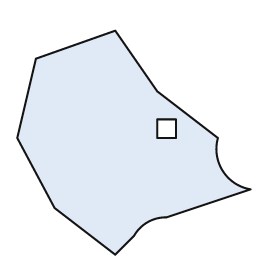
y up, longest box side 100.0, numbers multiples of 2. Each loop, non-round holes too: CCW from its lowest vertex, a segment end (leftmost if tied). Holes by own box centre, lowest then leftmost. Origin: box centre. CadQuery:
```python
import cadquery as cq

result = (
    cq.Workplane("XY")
    .moveTo(-8.0, -48.0)
    .lineTo(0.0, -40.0)
    .threePointArc((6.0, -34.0), (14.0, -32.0))
    .lineTo(50.0, -20.0)
    .threePointArc((38.0, -12.0), (36.0, 2.0))
    .lineTo(10.0, 22.0)
    .lineTo(-8.0, 48.0)
    .lineTo(-42.0, 36.0)
    .lineTo(-50.0, 2.0)
    .lineTo(-34.0, -28.0)
    .close()
    .moveTo(10.0, 2.0)
    .lineTo(18.0, 2.0)
    .lineTo(18.0, 10.0)
    .lineTo(10.0, 10.0)
    .close()
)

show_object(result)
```